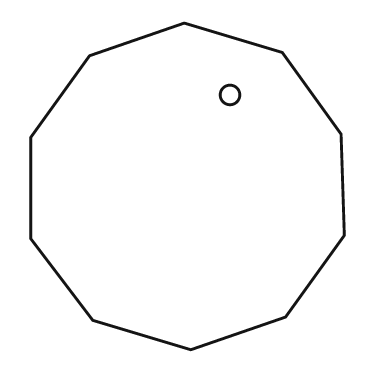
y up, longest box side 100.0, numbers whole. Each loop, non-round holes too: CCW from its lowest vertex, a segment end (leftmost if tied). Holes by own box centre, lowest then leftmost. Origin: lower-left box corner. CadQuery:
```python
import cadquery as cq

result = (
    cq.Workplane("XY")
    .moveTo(49.0, 0.0)
    .lineTo(78.0, 10.0)
    .lineTo(96.0, 35.0)
    .lineTo(95.0, 66.0)
    .lineTo(77.0, 91.0)
    .lineTo(47.0, 100.0)
    .lineTo(18.0, 90.0)
    .lineTo(0.0, 65.0)
    .lineTo(0.0, 34.0)
    .lineTo(19.0, 9.0)
    .close()
    .moveTo(61.0, 78.0)
    .circle(3.0)
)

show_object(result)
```